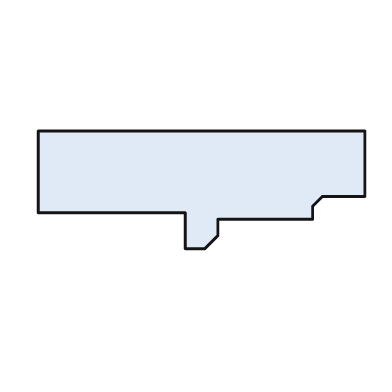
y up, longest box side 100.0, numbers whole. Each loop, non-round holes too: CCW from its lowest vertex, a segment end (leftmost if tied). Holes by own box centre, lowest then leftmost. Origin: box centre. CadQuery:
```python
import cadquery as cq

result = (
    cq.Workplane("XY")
    .moveTo(-5.0, -18.0)
    .lineTo(1.0, -18.0)
    .lineTo(5.0, -14.0)
    .lineTo(5.0, -9.0)
    .lineTo(34.0, -9.0)
    .lineTo(34.0, -5.0)
    .lineTo(37.0, -2.0)
    .lineTo(50.0, -2.0)
    .lineTo(50.0, 18.0)
    .lineTo(-50.0, 18.0)
    .lineTo(-50.0, -7.0)
    .lineTo(-5.0, -7.0)
    .close()
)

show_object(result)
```